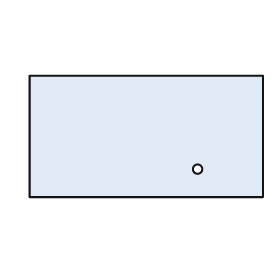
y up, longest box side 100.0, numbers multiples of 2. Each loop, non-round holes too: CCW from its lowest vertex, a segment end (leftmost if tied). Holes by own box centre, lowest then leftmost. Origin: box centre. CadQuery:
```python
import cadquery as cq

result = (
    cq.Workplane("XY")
    .moveTo(-50.0, -26.0)
    .lineTo(50.0, -26.0)
    .lineTo(50.0, 26.0)
    .lineTo(-50.0, 26.0)
    .close()
    .moveTo(22.0, -14.0)
    .circle(2.0)
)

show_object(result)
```